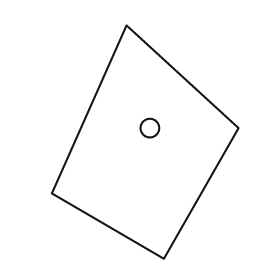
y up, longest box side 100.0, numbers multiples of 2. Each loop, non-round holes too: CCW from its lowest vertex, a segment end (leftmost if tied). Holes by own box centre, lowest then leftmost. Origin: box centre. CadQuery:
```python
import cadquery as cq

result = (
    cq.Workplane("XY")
    .moveTo(8.0, -50.0)
    .lineTo(40.0, 6.0)
    .lineTo(-8.0, 50.0)
    .lineTo(-40.0, -22.0)
    .close()
    .moveTo(2.0, 6.0)
    .circle(4.0)
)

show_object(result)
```